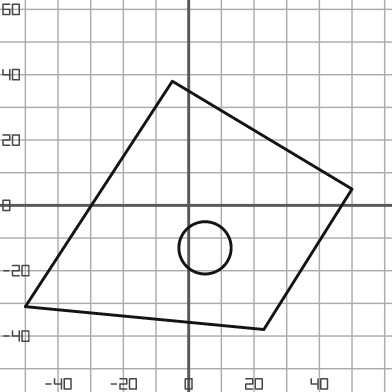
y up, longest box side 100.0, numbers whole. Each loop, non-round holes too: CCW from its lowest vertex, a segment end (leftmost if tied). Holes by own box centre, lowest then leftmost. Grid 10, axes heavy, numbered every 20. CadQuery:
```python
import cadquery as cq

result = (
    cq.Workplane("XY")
    .moveTo(23.0, -38.0)
    .lineTo(50.0, 5.0)
    .lineTo(-5.0, 38.0)
    .lineTo(-50.0, -31.0)
    .close()
    .moveTo(5.0, -13.0)
    .circle(8.0)
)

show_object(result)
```